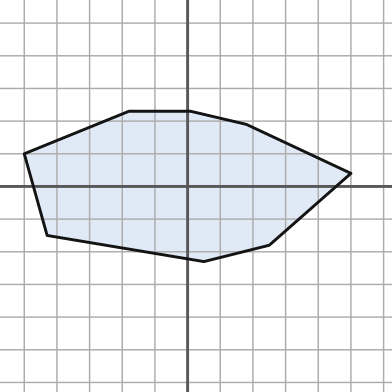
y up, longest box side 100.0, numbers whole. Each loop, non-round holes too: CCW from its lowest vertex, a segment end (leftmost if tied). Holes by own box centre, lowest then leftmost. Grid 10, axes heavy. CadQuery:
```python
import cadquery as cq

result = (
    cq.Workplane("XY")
    .moveTo(5.0, -23.0)
    .lineTo(25.0, -18.0)
    .lineTo(50.0, 4.0)
    .lineTo(18.0, 19.0)
    .lineTo(1.0, 23.0)
    .lineTo(-18.0, 23.0)
    .lineTo(-50.0, 10.0)
    .lineTo(-43.0, -15.0)
    .close()
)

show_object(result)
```